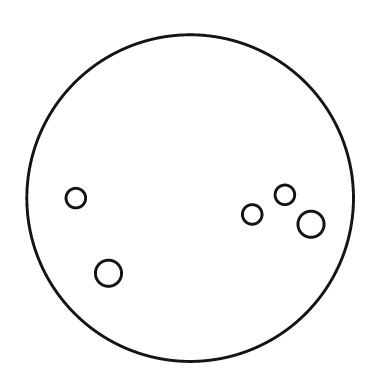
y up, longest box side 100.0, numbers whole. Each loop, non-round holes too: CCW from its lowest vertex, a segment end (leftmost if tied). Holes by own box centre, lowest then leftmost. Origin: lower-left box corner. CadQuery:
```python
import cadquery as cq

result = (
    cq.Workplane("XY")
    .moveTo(50.0, 50.0)
    .circle(50.0)
    .moveTo(25.0, 27.0)
    .circle(4.0)
    .moveTo(87.0, 42.0)
    .circle(4.0)
    .moveTo(69.0, 45.0)
    .circle(3.0)
    .moveTo(15.0, 50.0)
    .circle(3.0)
    .moveTo(79.0, 51.0)
    .circle(3.0)
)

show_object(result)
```